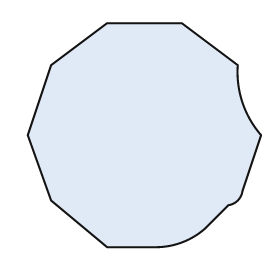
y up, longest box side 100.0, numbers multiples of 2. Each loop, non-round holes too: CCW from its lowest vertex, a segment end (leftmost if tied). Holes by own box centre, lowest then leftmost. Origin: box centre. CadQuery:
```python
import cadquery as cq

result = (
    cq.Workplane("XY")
    .moveTo(-16.0, -48.0)
    .lineTo(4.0, -48.0)
    .threePointArc((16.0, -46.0), (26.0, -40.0))
    .lineTo(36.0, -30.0)
    .threePointArc((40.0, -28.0), (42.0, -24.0))
    .lineTo(50.0, 0.0)
    .threePointArc((42.0, 14.0), (40.0, 30.0))
    .lineTo(16.0, 48.0)
    .lineTo(-16.0, 48.0)
    .lineTo(-40.0, 30.0)
    .lineTo(-50.0, 0.0)
    .lineTo(-40.0, -28.0)
    .close()
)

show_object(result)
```